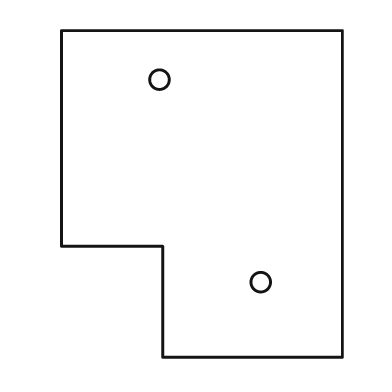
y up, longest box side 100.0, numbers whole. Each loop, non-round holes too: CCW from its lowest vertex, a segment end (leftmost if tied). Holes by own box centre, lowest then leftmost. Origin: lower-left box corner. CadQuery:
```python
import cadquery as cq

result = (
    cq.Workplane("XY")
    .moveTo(31.0, 0.0)
    .lineTo(86.0, 0.0)
    .lineTo(86.0, 100.0)
    .lineTo(0.0, 100.0)
    .lineTo(0.0, 34.0)
    .lineTo(31.0, 34.0)
    .close()
    .moveTo(61.0, 23.0)
    .circle(3.0)
    .moveTo(30.0, 85.0)
    .circle(3.0)
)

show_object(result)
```